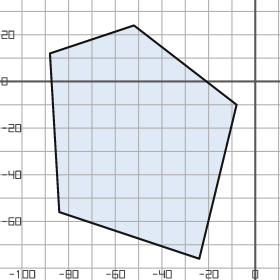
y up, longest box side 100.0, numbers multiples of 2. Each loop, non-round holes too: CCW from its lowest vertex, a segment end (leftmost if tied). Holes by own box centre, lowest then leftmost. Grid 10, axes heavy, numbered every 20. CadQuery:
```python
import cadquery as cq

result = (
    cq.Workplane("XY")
    .moveTo(-24.0, -76.0)
    .lineTo(-8.0, -10.0)
    .lineTo(-52.0, 24.0)
    .lineTo(-88.0, 12.0)
    .lineTo(-84.0, -56.0)
    .close()
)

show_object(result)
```